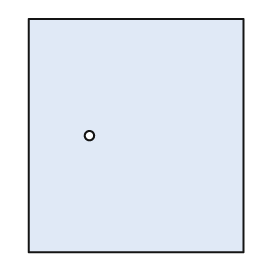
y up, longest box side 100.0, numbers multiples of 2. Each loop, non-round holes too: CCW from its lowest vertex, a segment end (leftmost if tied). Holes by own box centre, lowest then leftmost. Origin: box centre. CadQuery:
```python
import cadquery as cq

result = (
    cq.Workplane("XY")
    .moveTo(-46.0, -50.0)
    .lineTo(46.0, -50.0)
    .lineTo(46.0, 50.0)
    .lineTo(-46.0, 50.0)
    .close()
    .moveTo(-20.0, 0.0)
    .circle(2.0)
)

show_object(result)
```